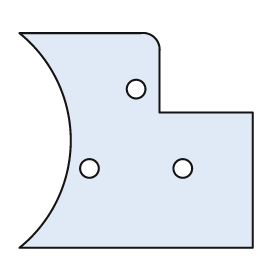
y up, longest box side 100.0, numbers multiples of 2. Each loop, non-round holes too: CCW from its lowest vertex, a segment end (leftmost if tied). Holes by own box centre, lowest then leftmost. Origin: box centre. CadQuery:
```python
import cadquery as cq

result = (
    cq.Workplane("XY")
    .moveTo(-50.0, -46.0)
    .lineTo(50.0, -46.0)
    .lineTo(50.0, 12.0)
    .lineTo(10.0, 12.0)
    .lineTo(10.0, 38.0)
    .threePointArc((8.0, 44.0), (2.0, 46.0))
    .lineTo(-50.0, 46.0)
    .threePointArc((-28.0, 0.0), (-50.0, -46.0))
    .close()
    .moveTo(-20.0, -12.0)
    .circle(4.0)
    .moveTo(20.0, -12.0)
    .circle(4.0)
    .moveTo(0.0, 22.0)
    .circle(4.0)
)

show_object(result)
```